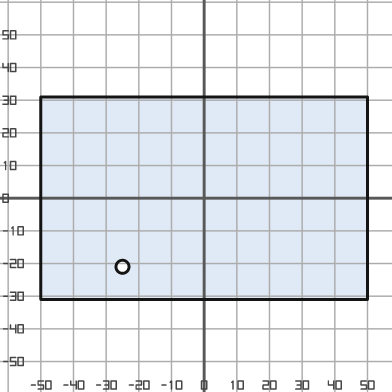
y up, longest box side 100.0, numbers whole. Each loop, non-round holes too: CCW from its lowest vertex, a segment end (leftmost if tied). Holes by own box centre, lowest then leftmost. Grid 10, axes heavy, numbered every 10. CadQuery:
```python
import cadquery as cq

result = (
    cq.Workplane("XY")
    .moveTo(-50.0, -31.0)
    .lineTo(50.0, -31.0)
    .lineTo(50.0, 31.0)
    .lineTo(-50.0, 31.0)
    .close()
    .moveTo(-25.0, -21.0)
    .circle(2.0)
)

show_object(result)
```